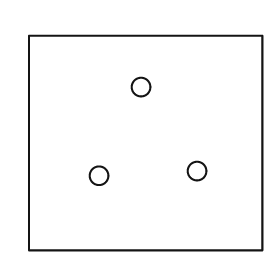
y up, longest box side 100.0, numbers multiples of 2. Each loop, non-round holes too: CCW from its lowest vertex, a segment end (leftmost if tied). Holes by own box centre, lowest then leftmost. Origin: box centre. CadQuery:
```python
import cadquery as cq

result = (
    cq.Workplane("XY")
    .moveTo(-50.0, -46.0)
    .lineTo(50.0, -46.0)
    .lineTo(50.0, 46.0)
    .lineTo(-50.0, 46.0)
    .close()
    .moveTo(-20.0, -14.0)
    .circle(4.0)
    .moveTo(22.0, -12.0)
    .circle(4.0)
    .moveTo(-2.0, 24.0)
    .circle(4.0)
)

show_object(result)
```